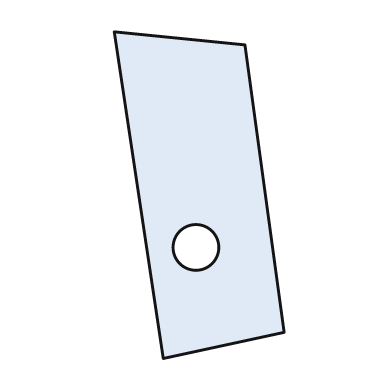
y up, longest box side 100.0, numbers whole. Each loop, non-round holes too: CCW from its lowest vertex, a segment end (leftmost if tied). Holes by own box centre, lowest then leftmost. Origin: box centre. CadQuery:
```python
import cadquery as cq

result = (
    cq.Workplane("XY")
    .moveTo(-11.0, -50.0)
    .lineTo(26.0, -42.0)
    .lineTo(14.0, 46.0)
    .lineTo(-26.0, 50.0)
    .close()
    .moveTo(-1.0, -16.0)
    .circle(7.0)
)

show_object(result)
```